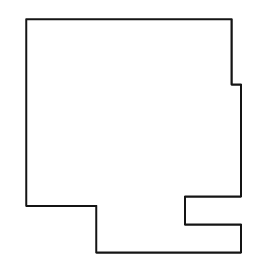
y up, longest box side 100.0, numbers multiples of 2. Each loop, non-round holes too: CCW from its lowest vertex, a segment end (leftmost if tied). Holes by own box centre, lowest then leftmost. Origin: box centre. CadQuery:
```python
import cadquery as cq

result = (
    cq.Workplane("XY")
    .moveTo(-16.0, -50.0)
    .lineTo(46.0, -50.0)
    .lineTo(46.0, -38.0)
    .lineTo(22.0, -38.0)
    .lineTo(22.0, -26.0)
    .lineTo(46.0, -26.0)
    .lineTo(46.0, 22.0)
    .lineTo(42.0, 22.0)
    .lineTo(42.0, 50.0)
    .lineTo(-46.0, 50.0)
    .lineTo(-46.0, -30.0)
    .lineTo(-16.0, -30.0)
    .close()
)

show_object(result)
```